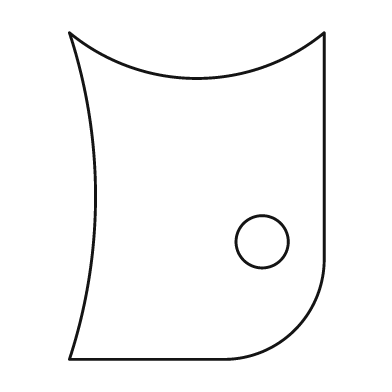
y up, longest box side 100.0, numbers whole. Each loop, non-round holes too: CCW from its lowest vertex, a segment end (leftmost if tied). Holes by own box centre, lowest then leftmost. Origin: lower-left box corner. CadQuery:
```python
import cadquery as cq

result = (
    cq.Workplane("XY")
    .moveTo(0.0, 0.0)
    .lineTo(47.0, 0.0)
    .threePointArc((69.0, 9.0), (78.0, 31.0))
    .lineTo(78.0, 100.0)
    .threePointArc((39.0, 86.0), (0.0, 100.0))
    .threePointArc((8.0, 50.0), (0.0, 0.0))
    .close()
    .moveTo(59.0, 36.0)
    .circle(8.0)
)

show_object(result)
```